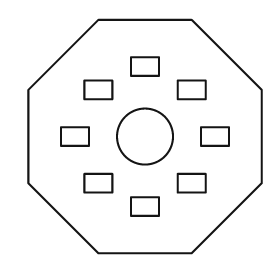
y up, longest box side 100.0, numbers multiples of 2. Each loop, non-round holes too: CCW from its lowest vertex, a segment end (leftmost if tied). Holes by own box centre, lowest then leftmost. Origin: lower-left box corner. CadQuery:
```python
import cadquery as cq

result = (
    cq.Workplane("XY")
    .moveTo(30.0, 0.0)
    .lineTo(70.0, 0.0)
    .lineTo(100.0, 30.0)
    .lineTo(100.0, 70.0)
    .lineTo(70.0, 100.0)
    .lineTo(30.0, 100.0)
    .lineTo(0.0, 70.0)
    .lineTo(0.0, 30.0)
    .close()
    .moveTo(44.0, 16.0)
    .lineTo(56.0, 16.0)
    .lineTo(56.0, 24.0)
    .lineTo(44.0, 24.0)
    .close()
    .moveTo(24.0, 26.0)
    .lineTo(36.0, 26.0)
    .lineTo(36.0, 34.0)
    .lineTo(24.0, 34.0)
    .close()
    .moveTo(64.0, 26.0)
    .lineTo(76.0, 26.0)
    .lineTo(76.0, 34.0)
    .lineTo(64.0, 34.0)
    .close()
    .moveTo(14.0, 46.0)
    .lineTo(26.0, 46.0)
    .lineTo(26.0, 54.0)
    .lineTo(14.0, 54.0)
    .close()
    .moveTo(50.0, 50.0)
    .circle(12.0)
    .moveTo(74.0, 46.0)
    .lineTo(86.0, 46.0)
    .lineTo(86.0, 54.0)
    .lineTo(74.0, 54.0)
    .close()
    .moveTo(24.0, 66.0)
    .lineTo(36.0, 66.0)
    .lineTo(36.0, 74.0)
    .lineTo(24.0, 74.0)
    .close()
    .moveTo(64.0, 66.0)
    .lineTo(76.0, 66.0)
    .lineTo(76.0, 74.0)
    .lineTo(64.0, 74.0)
    .close()
    .moveTo(44.0, 76.0)
    .lineTo(56.0, 76.0)
    .lineTo(56.0, 84.0)
    .lineTo(44.0, 84.0)
    .close()
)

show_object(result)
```